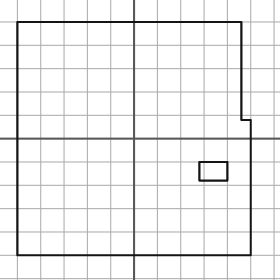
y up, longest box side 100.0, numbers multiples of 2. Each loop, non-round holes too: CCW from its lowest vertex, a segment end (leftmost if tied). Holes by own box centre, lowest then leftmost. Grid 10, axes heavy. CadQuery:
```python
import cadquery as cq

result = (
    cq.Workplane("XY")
    .moveTo(-50.0, -50.0)
    .lineTo(50.0, -50.0)
    .lineTo(50.0, 8.0)
    .lineTo(46.0, 8.0)
    .lineTo(46.0, 50.0)
    .lineTo(-50.0, 50.0)
    .close()
    .moveTo(28.0, -18.0)
    .lineTo(40.0, -18.0)
    .lineTo(40.0, -10.0)
    .lineTo(28.0, -10.0)
    .close()
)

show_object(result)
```